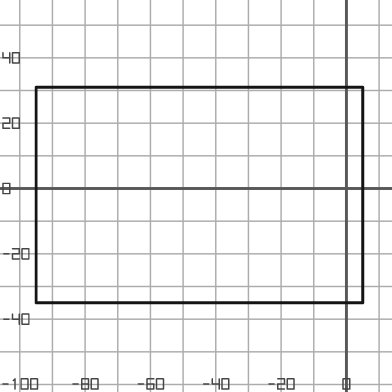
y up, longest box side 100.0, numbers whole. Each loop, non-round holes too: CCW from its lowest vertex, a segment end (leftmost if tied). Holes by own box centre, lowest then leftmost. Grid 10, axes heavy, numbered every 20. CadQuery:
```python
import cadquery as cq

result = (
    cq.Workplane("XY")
    .moveTo(-95.0, -35.0)
    .lineTo(5.0, -35.0)
    .lineTo(5.0, 31.0)
    .lineTo(-95.0, 31.0)
    .close()
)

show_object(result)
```